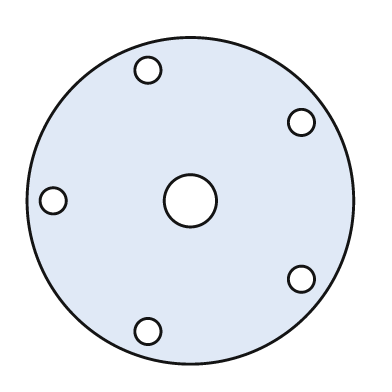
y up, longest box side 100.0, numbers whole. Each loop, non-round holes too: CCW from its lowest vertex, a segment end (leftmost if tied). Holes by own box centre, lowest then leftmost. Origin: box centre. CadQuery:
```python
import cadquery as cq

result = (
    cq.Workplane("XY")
    .moveTo(0.0, 0.0)
    .circle(50.0)
    .moveTo(-13.0, -40.0)
    .circle(4.0)
    .moveTo(34.0, -24.0)
    .circle(4.0)
    .moveTo(-42.0, 0.0)
    .circle(4.0)
    .moveTo(0.0, 0.0)
    .circle(8.0)
    .moveTo(34.0, 24.0)
    .circle(4.0)
    .moveTo(-13.0, 40.0)
    .circle(4.0)
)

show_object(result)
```